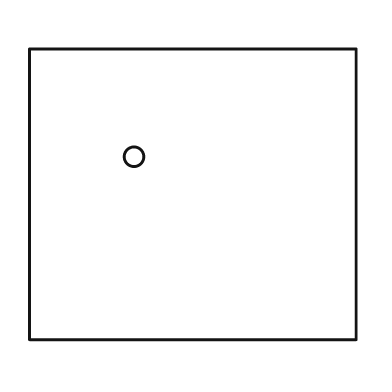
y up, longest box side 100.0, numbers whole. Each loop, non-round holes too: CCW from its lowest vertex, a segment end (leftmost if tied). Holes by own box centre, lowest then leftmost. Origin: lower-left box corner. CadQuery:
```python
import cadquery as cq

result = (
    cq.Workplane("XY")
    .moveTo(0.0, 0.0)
    .lineTo(100.0, 0.0)
    .lineTo(100.0, 89.0)
    .lineTo(0.0, 89.0)
    .close()
    .moveTo(32.0, 56.0)
    .circle(3.0)
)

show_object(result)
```